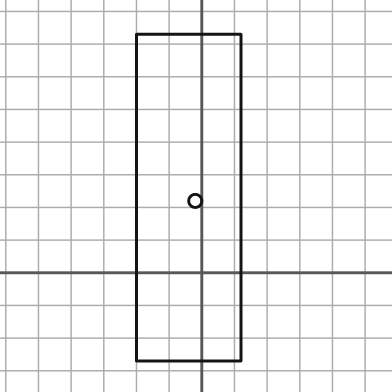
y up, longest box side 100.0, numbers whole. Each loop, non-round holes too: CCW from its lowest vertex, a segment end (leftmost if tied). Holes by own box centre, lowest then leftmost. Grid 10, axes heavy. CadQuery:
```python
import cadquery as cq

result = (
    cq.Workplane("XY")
    .moveTo(-20.0, -27.0)
    .lineTo(12.0, -27.0)
    .lineTo(12.0, 73.0)
    .lineTo(-20.0, 73.0)
    .close()
    .moveTo(-2.0, 22.0)
    .circle(2.0)
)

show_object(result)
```